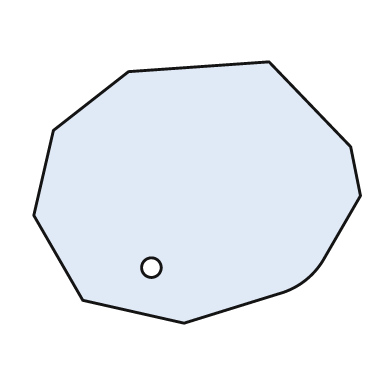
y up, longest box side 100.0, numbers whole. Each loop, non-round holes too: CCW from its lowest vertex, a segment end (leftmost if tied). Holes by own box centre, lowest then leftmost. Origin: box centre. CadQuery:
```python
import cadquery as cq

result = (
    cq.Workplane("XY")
    .moveTo(-4.0, -40.0)
    .lineTo(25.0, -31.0)
    .threePointArc((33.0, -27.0), (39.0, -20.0))
    .lineTo(50.0, -1.0)
    .lineTo(47.0, 14.0)
    .lineTo(22.0, 40.0)
    .lineTo(-21.0, 37.0)
    .lineTo(-44.0, 19.0)
    .lineTo(-50.0, -7.0)
    .lineTo(-35.0, -33.0)
    .close()
    .moveTo(-14.0, -23.0)
    .circle(3.0)
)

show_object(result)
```